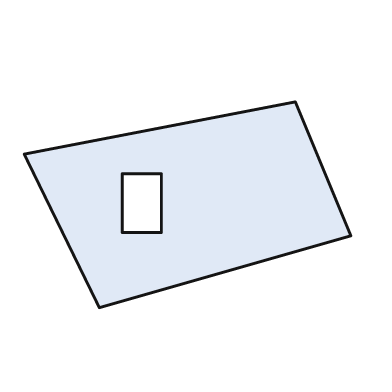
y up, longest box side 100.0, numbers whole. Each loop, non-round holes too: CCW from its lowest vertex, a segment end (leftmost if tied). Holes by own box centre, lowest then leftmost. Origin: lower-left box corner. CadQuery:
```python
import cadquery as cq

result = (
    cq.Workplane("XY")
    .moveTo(23.0, 0.0)
    .lineTo(100.0, 22.0)
    .lineTo(83.0, 63.0)
    .lineTo(0.0, 47.0)
    .close()
    .moveTo(30.0, 23.0)
    .lineTo(42.0, 23.0)
    .lineTo(42.0, 41.0)
    .lineTo(30.0, 41.0)
    .close()
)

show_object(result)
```